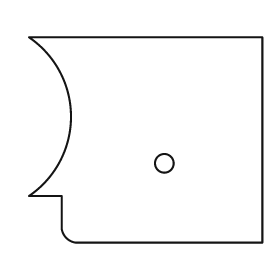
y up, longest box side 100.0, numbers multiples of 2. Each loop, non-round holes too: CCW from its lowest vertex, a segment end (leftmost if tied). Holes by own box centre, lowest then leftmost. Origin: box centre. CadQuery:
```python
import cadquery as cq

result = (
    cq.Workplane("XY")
    .moveTo(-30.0, -44.0)
    .lineTo(50.0, -44.0)
    .lineTo(50.0, 44.0)
    .lineTo(-50.0, 44.0)
    .threePointArc((-32.0, 10.0), (-50.0, -24.0))
    .lineTo(-36.0, -24.0)
    .lineTo(-36.0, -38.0)
    .threePointArc((-34.0, -42.0), (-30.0, -44.0))
    .close()
    .moveTo(8.0, -10.0)
    .circle(4.0)
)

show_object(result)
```